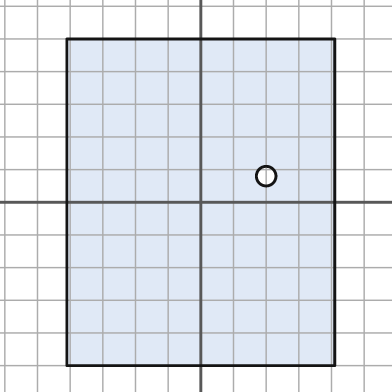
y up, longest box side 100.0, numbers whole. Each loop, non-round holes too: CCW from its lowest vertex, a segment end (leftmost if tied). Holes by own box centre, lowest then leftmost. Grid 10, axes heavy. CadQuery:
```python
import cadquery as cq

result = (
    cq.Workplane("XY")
    .moveTo(-41.0, -50.0)
    .lineTo(41.0, -50.0)
    .lineTo(41.0, 50.0)
    .lineTo(-41.0, 50.0)
    .close()
    .moveTo(20.0, 8.0)
    .circle(3.0)
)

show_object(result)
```